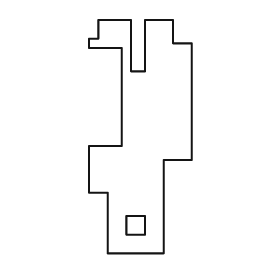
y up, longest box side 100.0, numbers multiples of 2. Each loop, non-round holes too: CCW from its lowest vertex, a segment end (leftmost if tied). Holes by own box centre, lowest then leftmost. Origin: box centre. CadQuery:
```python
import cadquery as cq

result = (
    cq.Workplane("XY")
    .moveTo(-14.0, -50.0)
    .lineTo(10.0, -50.0)
    .lineTo(10.0, -10.0)
    .lineTo(22.0, -10.0)
    .lineTo(22.0, 40.0)
    .lineTo(14.0, 40.0)
    .lineTo(14.0, 50.0)
    .lineTo(2.0, 50.0)
    .lineTo(2.0, 28.0)
    .lineTo(-4.0, 28.0)
    .lineTo(-4.0, 50.0)
    .lineTo(-18.0, 50.0)
    .lineTo(-18.0, 42.0)
    .lineTo(-22.0, 42.0)
    .lineTo(-22.0, 38.0)
    .lineTo(-8.0, 38.0)
    .lineTo(-8.0, -4.0)
    .lineTo(-22.0, -4.0)
    .lineTo(-22.0, -24.0)
    .lineTo(-14.0, -24.0)
    .close()
    .moveTo(-6.0, -42.0)
    .lineTo(2.0, -42.0)
    .lineTo(2.0, -34.0)
    .lineTo(-6.0, -34.0)
    .close()
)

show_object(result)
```